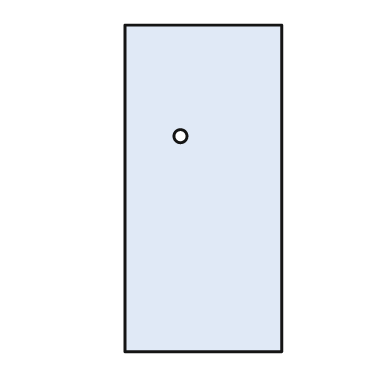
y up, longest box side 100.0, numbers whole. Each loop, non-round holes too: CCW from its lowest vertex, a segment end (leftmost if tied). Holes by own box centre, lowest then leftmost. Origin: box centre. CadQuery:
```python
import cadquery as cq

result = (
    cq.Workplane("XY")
    .moveTo(-24.0, -50.0)
    .lineTo(24.0, -50.0)
    .lineTo(24.0, 50.0)
    .lineTo(-24.0, 50.0)
    .close()
    .moveTo(-7.0, 16.0)
    .circle(2.0)
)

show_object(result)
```